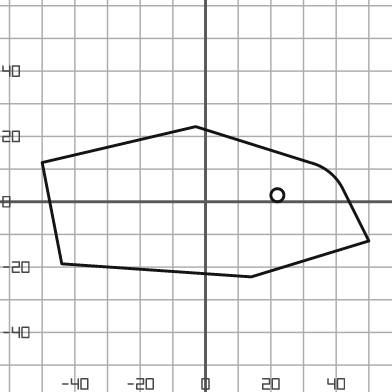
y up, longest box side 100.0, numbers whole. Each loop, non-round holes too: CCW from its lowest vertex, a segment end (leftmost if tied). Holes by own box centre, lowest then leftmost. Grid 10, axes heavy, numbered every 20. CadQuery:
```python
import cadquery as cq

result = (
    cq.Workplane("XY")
    .moveTo(14.0, -23.0)
    .lineTo(50.0, -12.0)
    .lineTo(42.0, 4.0)
    .threePointArc((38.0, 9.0), (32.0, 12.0))
    .lineTo(-3.0, 23.0)
    .lineTo(-50.0, 12.0)
    .lineTo(-44.0, -19.0)
    .close()
    .moveTo(22.0, 2.0)
    .circle(2.0)
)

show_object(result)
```